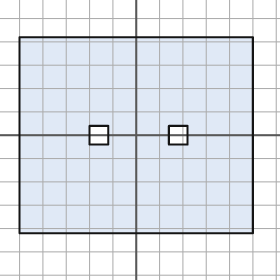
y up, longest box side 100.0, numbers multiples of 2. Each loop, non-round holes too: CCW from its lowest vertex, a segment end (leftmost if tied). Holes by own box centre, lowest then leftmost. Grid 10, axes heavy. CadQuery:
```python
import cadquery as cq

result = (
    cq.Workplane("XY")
    .moveTo(-50.0, -42.0)
    .lineTo(50.0, -42.0)
    .lineTo(50.0, 42.0)
    .lineTo(-50.0, 42.0)
    .close()
    .moveTo(-20.0, -4.0)
    .lineTo(-12.0, -4.0)
    .lineTo(-12.0, 4.0)
    .lineTo(-20.0, 4.0)
    .close()
    .moveTo(14.0, -4.0)
    .lineTo(22.0, -4.0)
    .lineTo(22.0, 4.0)
    .lineTo(14.0, 4.0)
    .close()
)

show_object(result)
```